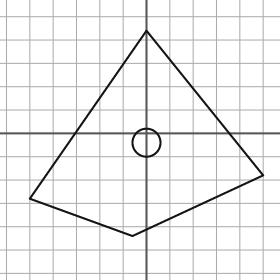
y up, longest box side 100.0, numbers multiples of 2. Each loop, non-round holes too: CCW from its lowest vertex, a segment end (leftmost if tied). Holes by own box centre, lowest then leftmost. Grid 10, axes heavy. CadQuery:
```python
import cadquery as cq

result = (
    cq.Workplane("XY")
    .moveTo(-6.0, -44.0)
    .lineTo(50.0, -18.0)
    .lineTo(0.0, 44.0)
    .lineTo(-50.0, -28.0)
    .close()
    .moveTo(0.0, -4.0)
    .circle(6.0)
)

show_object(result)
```